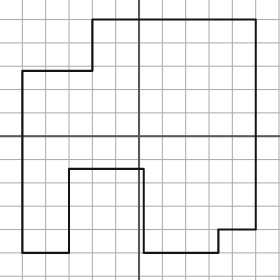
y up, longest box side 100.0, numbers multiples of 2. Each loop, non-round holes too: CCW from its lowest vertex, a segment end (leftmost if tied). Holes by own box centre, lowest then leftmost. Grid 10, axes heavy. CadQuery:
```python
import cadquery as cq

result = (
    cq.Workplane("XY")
    .moveTo(-50.0, -50.0)
    .lineTo(-30.0, -50.0)
    .lineTo(-30.0, -14.0)
    .lineTo(2.0, -14.0)
    .lineTo(2.0, -50.0)
    .lineTo(34.0, -50.0)
    .lineTo(34.0, -40.0)
    .lineTo(50.0, -40.0)
    .lineTo(50.0, 50.0)
    .lineTo(-20.0, 50.0)
    .lineTo(-20.0, 28.0)
    .lineTo(-50.0, 28.0)
    .close()
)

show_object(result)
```